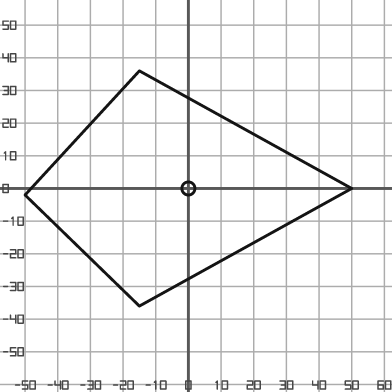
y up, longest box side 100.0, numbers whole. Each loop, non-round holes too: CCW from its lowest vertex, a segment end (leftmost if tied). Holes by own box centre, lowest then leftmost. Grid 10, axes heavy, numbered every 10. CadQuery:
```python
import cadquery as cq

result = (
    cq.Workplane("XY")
    .moveTo(-15.0, -36.0)
    .lineTo(50.0, 0.0)
    .lineTo(-15.0, 36.0)
    .lineTo(-50.0, -2.0)
    .close()
    .moveTo(0.0, 0.0)
    .circle(2.0)
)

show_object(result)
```